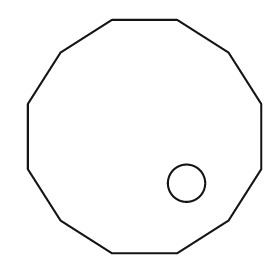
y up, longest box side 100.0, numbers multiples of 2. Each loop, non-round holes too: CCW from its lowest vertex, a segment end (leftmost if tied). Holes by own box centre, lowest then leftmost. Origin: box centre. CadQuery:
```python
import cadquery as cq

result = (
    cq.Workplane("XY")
    .moveTo(-14.0, -50.0)
    .lineTo(14.0, -50.0)
    .lineTo(36.0, -36.0)
    .lineTo(50.0, -14.0)
    .lineTo(50.0, 14.0)
    .lineTo(36.0, 36.0)
    .lineTo(14.0, 50.0)
    .lineTo(-14.0, 50.0)
    .lineTo(-36.0, 36.0)
    .lineTo(-50.0, 14.0)
    .lineTo(-50.0, -14.0)
    .lineTo(-36.0, -36.0)
    .close()
    .moveTo(18.0, -20.0)
    .circle(8.0)
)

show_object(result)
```